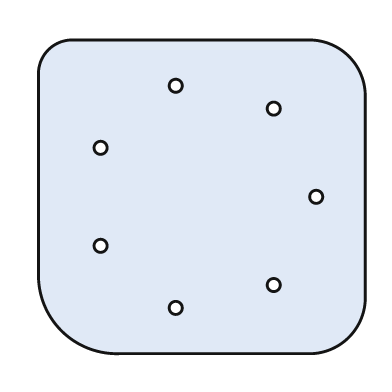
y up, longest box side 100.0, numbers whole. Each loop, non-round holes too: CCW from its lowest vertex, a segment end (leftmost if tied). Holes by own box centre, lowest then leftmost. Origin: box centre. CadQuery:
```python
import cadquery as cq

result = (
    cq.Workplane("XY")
    .moveTo(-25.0, -48.0)
    .lineTo(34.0, -48.0)
    .threePointArc((45.0, -43.0), (50.0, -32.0))
    .lineTo(50.0, 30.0)
    .threePointArc((45.0, 43.0), (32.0, 48.0))
    .lineTo(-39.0, 48.0)
    .threePointArc((-47.0, 45.0), (-50.0, 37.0))
    .lineTo(-50.0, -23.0)
    .threePointArc((-43.0, -41.0), (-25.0, -48.0))
    .close()
    .moveTo(-8.0, -34.0)
    .circle(2.0)
    .moveTo(22.0, -27.0)
    .circle(2.0)
    .moveTo(-31.0, -15.0)
    .circle(2.0)
    .moveTo(35.0, 0.0)
    .circle(2.0)
    .moveTo(-31.0, 15.0)
    .circle(2.0)
    .moveTo(22.0, 27.0)
    .circle(2.0)
    .moveTo(-8.0, 34.0)
    .circle(2.0)
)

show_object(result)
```